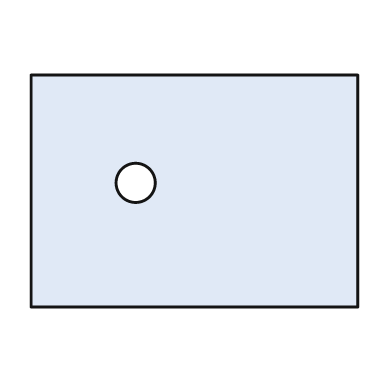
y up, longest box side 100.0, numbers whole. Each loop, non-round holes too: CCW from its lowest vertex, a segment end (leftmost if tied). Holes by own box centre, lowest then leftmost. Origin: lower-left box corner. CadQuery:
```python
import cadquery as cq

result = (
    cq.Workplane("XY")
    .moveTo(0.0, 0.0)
    .lineTo(100.0, 0.0)
    .lineTo(100.0, 71.0)
    .lineTo(0.0, 71.0)
    .close()
    .moveTo(32.0, 38.0)
    .circle(6.0)
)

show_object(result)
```